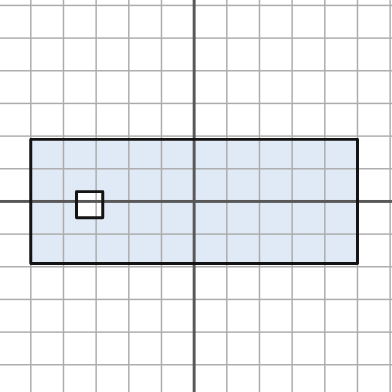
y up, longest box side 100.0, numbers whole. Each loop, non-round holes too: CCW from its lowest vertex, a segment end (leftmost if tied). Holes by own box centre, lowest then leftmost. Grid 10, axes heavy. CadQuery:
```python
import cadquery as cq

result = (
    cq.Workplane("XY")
    .moveTo(-50.0, -19.0)
    .lineTo(50.0, -19.0)
    .lineTo(50.0, 19.0)
    .lineTo(-50.0, 19.0)
    .close()
    .moveTo(-36.0, -5.0)
    .lineTo(-28.0, -5.0)
    .lineTo(-28.0, 3.0)
    .lineTo(-36.0, 3.0)
    .close()
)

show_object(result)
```